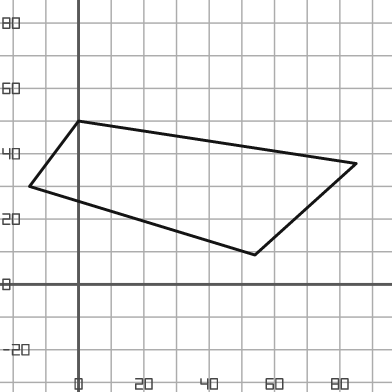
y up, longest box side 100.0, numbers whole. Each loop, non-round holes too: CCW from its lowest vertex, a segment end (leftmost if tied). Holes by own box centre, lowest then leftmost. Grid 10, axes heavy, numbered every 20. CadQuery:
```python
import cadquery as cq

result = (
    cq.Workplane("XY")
    .moveTo(54.0, 9.0)
    .lineTo(85.0, 37.0)
    .lineTo(0.0, 50.0)
    .lineTo(-15.0, 30.0)
    .close()
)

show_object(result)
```